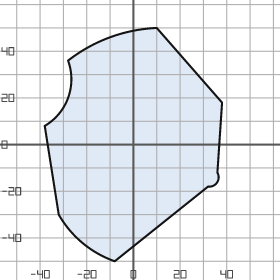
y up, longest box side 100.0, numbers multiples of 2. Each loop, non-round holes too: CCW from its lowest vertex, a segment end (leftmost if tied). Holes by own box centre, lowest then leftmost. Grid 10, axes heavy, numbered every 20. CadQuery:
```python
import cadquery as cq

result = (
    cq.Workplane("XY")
    .moveTo(-8.0, -50.0)
    .lineTo(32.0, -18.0)
    .threePointArc((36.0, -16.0), (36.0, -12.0))
    .lineTo(38.0, 18.0)
    .lineTo(10.0, 50.0)
    .threePointArc((-10.0, 46.0), (-28.0, 36.0))
    .threePointArc((-28.0, 20.0), (-38.0, 8.0))
    .lineTo(-32.0, -30.0)
    .threePointArc((-22.0, -42.0), (-8.0, -50.0))
    .close()
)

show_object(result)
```